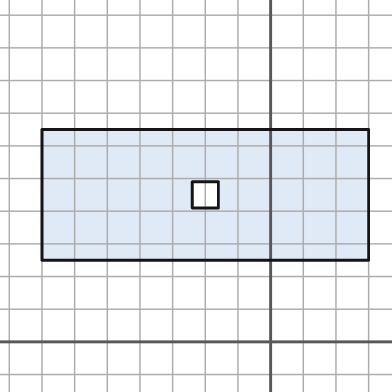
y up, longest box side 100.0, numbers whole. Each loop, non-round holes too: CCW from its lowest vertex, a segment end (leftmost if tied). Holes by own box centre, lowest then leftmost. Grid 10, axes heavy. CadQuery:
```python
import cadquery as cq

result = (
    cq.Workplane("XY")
    .moveTo(-70.0, 25.0)
    .lineTo(30.0, 25.0)
    .lineTo(30.0, 65.0)
    .lineTo(-70.0, 65.0)
    .close()
    .moveTo(-24.0, 41.0)
    .lineTo(-16.0, 41.0)
    .lineTo(-16.0, 49.0)
    .lineTo(-24.0, 49.0)
    .close()
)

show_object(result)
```